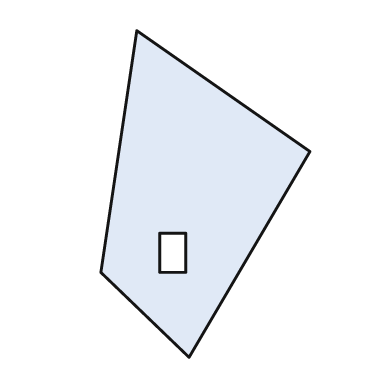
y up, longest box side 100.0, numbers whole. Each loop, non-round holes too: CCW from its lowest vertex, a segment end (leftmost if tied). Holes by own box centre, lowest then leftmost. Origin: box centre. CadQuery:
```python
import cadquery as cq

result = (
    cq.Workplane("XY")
    .moveTo(-5.0, -50.0)
    .lineTo(32.0, 13.0)
    .lineTo(-21.0, 50.0)
    .lineTo(-32.0, -24.0)
    .close()
    .moveTo(-14.0, -24.0)
    .lineTo(-6.0, -24.0)
    .lineTo(-6.0, -12.0)
    .lineTo(-14.0, -12.0)
    .close()
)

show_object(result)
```